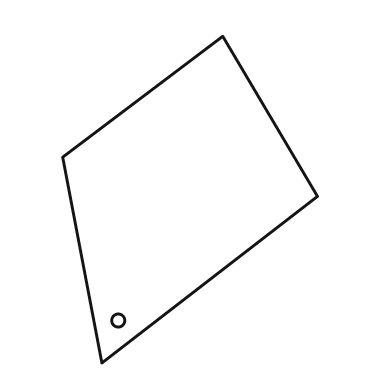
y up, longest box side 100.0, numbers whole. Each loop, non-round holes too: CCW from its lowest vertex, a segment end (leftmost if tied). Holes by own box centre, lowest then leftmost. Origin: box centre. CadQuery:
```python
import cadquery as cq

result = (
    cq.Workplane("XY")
    .moveTo(-27.0, -50.0)
    .lineTo(39.0, 1.0)
    .lineTo(10.0, 50.0)
    .lineTo(-39.0, 13.0)
    .close()
    .moveTo(-22.0, -37.0)
    .circle(2.0)
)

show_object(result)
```